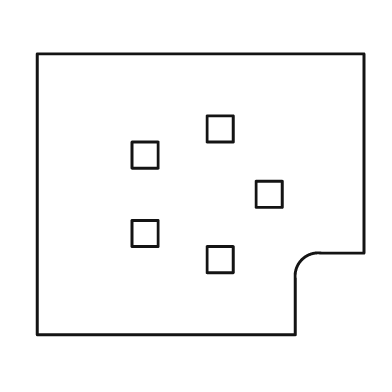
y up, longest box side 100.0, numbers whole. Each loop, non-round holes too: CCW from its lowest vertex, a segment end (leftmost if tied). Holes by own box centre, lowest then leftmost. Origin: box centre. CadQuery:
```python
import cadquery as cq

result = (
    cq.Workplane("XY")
    .moveTo(-50.0, -43.0)
    .lineTo(29.0, -43.0)
    .lineTo(29.0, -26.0)
    .threePointArc((31.0, -20.0), (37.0, -18.0))
    .lineTo(50.0, -18.0)
    .lineTo(50.0, 43.0)
    .lineTo(-50.0, 43.0)
    .close()
    .moveTo(2.0, -24.0)
    .lineTo(10.0, -24.0)
    .lineTo(10.0, -16.0)
    .lineTo(2.0, -16.0)
    .close()
    .moveTo(-21.0, -16.0)
    .lineTo(-13.0, -16.0)
    .lineTo(-13.0, -8.0)
    .lineTo(-21.0, -8.0)
    .close()
    .moveTo(17.0, -4.0)
    .lineTo(25.0, -4.0)
    .lineTo(25.0, 4.0)
    .lineTo(17.0, 4.0)
    .close()
    .moveTo(-21.0, 8.0)
    .lineTo(-13.0, 8.0)
    .lineTo(-13.0, 16.0)
    .lineTo(-21.0, 16.0)
    .close()
    .moveTo(2.0, 16.0)
    .lineTo(10.0, 16.0)
    .lineTo(10.0, 24.0)
    .lineTo(2.0, 24.0)
    .close()
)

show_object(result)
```